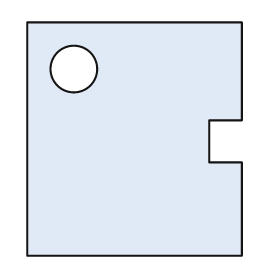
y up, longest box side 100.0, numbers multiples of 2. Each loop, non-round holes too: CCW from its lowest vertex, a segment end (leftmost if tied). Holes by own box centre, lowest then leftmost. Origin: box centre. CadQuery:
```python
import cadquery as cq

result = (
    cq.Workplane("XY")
    .moveTo(-46.0, -50.0)
    .lineTo(46.0, -50.0)
    .lineTo(46.0, -10.0)
    .lineTo(32.0, -10.0)
    .lineTo(32.0, 8.0)
    .lineTo(46.0, 8.0)
    .lineTo(46.0, 50.0)
    .lineTo(-46.0, 50.0)
    .close()
    .moveTo(-26.0, 30.0)
    .circle(10.0)
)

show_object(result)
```